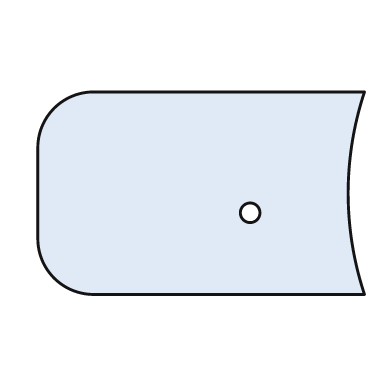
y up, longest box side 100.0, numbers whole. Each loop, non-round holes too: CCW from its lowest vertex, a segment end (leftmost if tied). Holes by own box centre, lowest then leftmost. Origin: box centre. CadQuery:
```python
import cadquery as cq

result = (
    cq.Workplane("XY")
    .moveTo(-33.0, -31.0)
    .lineTo(50.0, -31.0)
    .threePointArc((45.0, 0.0), (50.0, 31.0))
    .lineTo(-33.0, 31.0)
    .threePointArc((-45.0, 26.0), (-50.0, 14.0))
    .lineTo(-50.0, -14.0)
    .threePointArc((-45.0, -26.0), (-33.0, -31.0))
    .close()
    .moveTo(15.0, -6.0)
    .circle(3.0)
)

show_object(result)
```